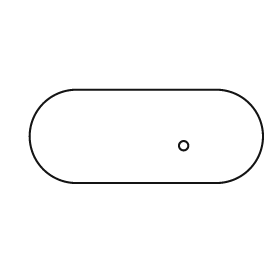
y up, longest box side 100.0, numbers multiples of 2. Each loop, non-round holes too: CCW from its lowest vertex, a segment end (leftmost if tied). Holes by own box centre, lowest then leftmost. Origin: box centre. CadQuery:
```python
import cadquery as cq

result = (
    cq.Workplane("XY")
    .moveTo(-30.0, -20.0)
    .lineTo(30.0, -20.0)
    .threePointArc((50.0, 0.0), (30.0, 20.0))
    .lineTo(-30.0, 20.0)
    .threePointArc((-50.0, 0.0), (-30.0, -20.0))
    .close()
    .moveTo(16.0, -4.0)
    .circle(2.0)
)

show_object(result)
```